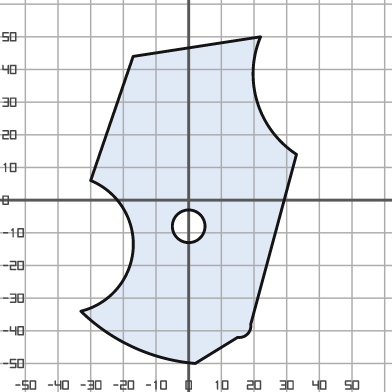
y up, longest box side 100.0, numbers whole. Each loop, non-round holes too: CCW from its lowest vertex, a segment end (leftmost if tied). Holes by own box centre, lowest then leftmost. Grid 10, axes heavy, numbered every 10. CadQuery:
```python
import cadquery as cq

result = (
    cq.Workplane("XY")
    .moveTo(2.0, -50.0)
    .lineTo(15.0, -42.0)
    .threePointArc((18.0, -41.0), (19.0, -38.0))
    .lineTo(33.0, 14.0)
    .threePointArc((21.0, 30.0), (22.0, 50.0))
    .lineTo(-17.0, 44.0)
    .lineTo(-30.0, 6.0)
    .threePointArc((-17.0, -15.0), (-33.0, -34.0))
    .threePointArc((-17.0, -45.0), (2.0, -50.0))
    .close()
    .moveTo(0.0, -8.0)
    .circle(5.0)
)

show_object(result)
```